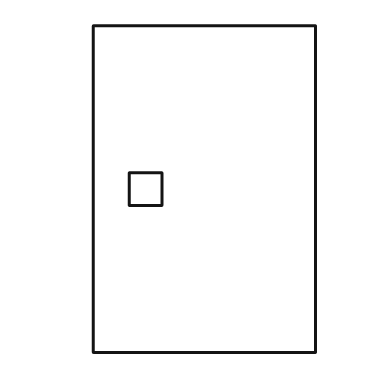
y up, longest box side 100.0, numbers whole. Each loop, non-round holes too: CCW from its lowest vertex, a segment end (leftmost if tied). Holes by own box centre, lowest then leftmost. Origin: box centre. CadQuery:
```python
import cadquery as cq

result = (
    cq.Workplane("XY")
    .moveTo(-34.0, -50.0)
    .lineTo(34.0, -50.0)
    .lineTo(34.0, 50.0)
    .lineTo(-34.0, 50.0)
    .close()
    .moveTo(-23.0, -5.0)
    .lineTo(-13.0, -5.0)
    .lineTo(-13.0, 5.0)
    .lineTo(-23.0, 5.0)
    .close()
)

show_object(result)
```